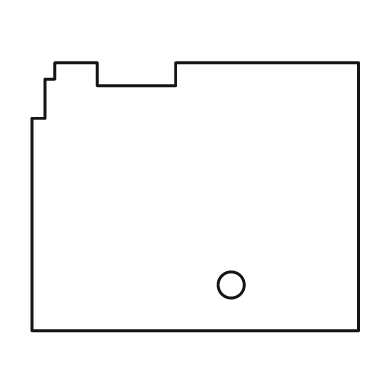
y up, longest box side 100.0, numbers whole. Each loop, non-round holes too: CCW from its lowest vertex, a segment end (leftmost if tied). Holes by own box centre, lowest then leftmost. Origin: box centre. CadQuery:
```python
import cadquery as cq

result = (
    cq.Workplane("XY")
    .moveTo(-50.0, -41.0)
    .lineTo(50.0, -41.0)
    .lineTo(50.0, 41.0)
    .lineTo(-6.0, 41.0)
    .lineTo(-6.0, 34.0)
    .lineTo(-30.0, 34.0)
    .lineTo(-30.0, 41.0)
    .lineTo(-43.0, 41.0)
    .lineTo(-43.0, 36.0)
    .lineTo(-46.0, 36.0)
    .lineTo(-46.0, 24.0)
    .lineTo(-50.0, 24.0)
    .close()
    .moveTo(11.0, -27.0)
    .circle(4.0)
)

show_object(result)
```